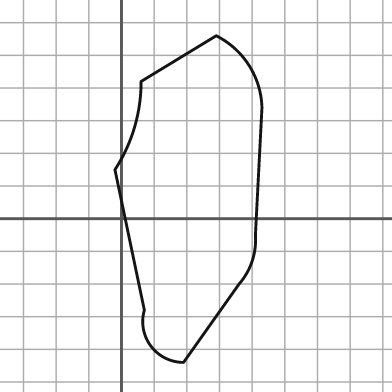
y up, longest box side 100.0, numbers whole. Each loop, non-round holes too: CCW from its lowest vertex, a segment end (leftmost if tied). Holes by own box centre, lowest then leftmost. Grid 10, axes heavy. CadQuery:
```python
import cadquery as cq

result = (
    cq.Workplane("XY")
    .moveTo(19.0, -44.0)
    .lineTo(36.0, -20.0)
    .threePointArc((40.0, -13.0), (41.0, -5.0))
    .lineTo(43.0, 34.0)
    .threePointArc((39.0, 47.0), (29.0, 56.0))
    .lineTo(6.0, 42.0)
    .threePointArc((4.0, 28.0), (-2.0, 15.0))
    .lineTo(7.0, -28.0)
    .threePointArc((9.0, -39.0), (19.0, -44.0))
    .close()
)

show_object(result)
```